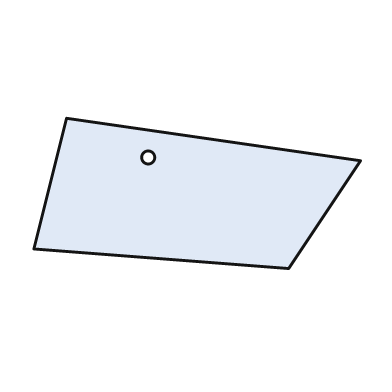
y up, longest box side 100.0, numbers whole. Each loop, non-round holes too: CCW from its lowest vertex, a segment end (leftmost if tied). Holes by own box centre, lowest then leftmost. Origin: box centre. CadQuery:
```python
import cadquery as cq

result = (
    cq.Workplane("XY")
    .moveTo(28.0, -23.0)
    .lineTo(50.0, 10.0)
    .lineTo(-40.0, 23.0)
    .lineTo(-50.0, -17.0)
    .close()
    .moveTo(-15.0, 11.0)
    .circle(2.0)
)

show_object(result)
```